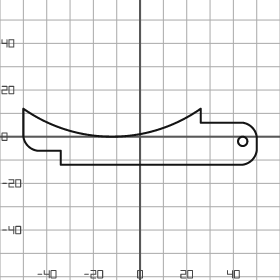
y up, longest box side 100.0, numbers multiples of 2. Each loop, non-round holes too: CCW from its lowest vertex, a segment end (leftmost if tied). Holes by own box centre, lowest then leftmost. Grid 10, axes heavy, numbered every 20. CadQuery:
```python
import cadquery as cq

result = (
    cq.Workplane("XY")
    .moveTo(-34.0, -12.0)
    .lineTo(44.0, -12.0)
    .threePointArc((48.0, -10.0), (50.0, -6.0))
    .lineTo(50.0, 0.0)
    .threePointArc((48.0, 4.0), (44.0, 6.0))
    .lineTo(26.0, 6.0)
    .lineTo(26.0, 12.0)
    .threePointArc((-12.0, 0.0), (-50.0, 12.0))
    .lineTo(-50.0, 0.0)
    .threePointArc((-48.0, -4.0), (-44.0, -6.0))
    .lineTo(-34.0, -6.0)
    .close()
    .moveTo(44.0, -2.0)
    .circle(2.0)
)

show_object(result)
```